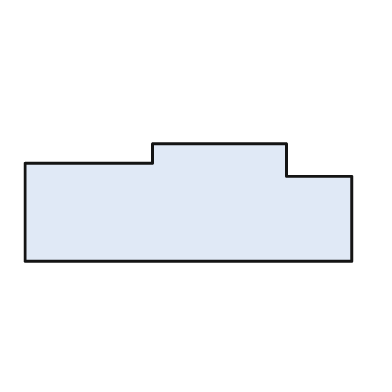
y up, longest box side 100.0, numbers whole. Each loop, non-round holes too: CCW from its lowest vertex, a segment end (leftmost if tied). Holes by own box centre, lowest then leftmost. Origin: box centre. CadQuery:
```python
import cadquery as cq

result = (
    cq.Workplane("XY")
    .moveTo(-50.0, -18.0)
    .lineTo(50.0, -18.0)
    .lineTo(50.0, 8.0)
    .lineTo(30.0, 8.0)
    .lineTo(30.0, 18.0)
    .lineTo(-11.0, 18.0)
    .lineTo(-11.0, 12.0)
    .lineTo(-50.0, 12.0)
    .close()
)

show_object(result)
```